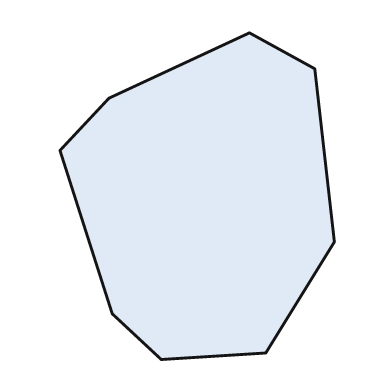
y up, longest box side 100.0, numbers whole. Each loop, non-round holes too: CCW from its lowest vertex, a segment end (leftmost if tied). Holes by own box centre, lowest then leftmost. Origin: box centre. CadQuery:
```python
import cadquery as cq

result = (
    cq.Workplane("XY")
    .moveTo(-11.0, -50.0)
    .lineTo(21.0, -48.0)
    .lineTo(42.0, -14.0)
    .lineTo(36.0, 39.0)
    .lineTo(16.0, 50.0)
    .lineTo(-27.0, 30.0)
    .lineTo(-42.0, 14.0)
    .lineTo(-26.0, -36.0)
    .close()
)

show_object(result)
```